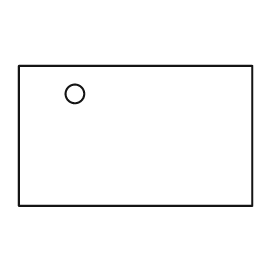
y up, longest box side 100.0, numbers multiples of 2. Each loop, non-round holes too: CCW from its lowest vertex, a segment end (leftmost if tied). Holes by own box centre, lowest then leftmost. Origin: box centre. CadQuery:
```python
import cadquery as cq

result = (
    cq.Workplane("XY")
    .moveTo(-50.0, -30.0)
    .lineTo(50.0, -30.0)
    .lineTo(50.0, 30.0)
    .lineTo(-50.0, 30.0)
    .close()
    .moveTo(-26.0, 18.0)
    .circle(4.0)
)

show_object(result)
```